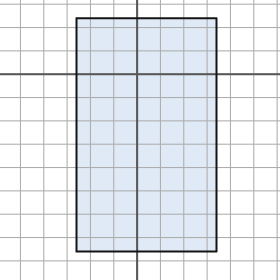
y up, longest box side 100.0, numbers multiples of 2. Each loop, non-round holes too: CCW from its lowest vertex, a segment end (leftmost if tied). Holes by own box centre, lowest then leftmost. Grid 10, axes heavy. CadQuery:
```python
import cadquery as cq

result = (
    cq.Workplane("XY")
    .moveTo(-26.0, -76.0)
    .lineTo(34.0, -76.0)
    .lineTo(34.0, 24.0)
    .lineTo(-26.0, 24.0)
    .close()
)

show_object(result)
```